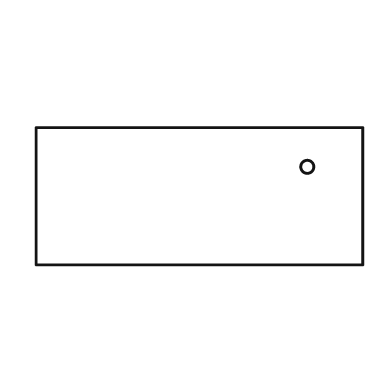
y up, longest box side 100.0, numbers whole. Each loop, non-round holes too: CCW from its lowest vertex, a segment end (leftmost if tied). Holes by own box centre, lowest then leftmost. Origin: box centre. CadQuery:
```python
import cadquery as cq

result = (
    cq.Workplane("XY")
    .moveTo(-50.0, -21.0)
    .lineTo(50.0, -21.0)
    .lineTo(50.0, 21.0)
    .lineTo(-50.0, 21.0)
    .close()
    .moveTo(33.0, 9.0)
    .circle(2.0)
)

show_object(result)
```